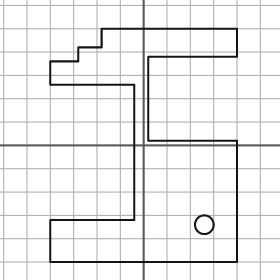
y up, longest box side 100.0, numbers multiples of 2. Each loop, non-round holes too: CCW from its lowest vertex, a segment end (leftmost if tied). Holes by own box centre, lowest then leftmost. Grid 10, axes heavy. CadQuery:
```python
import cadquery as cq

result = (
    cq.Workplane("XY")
    .moveTo(-40.0, -50.0)
    .lineTo(40.0, -50.0)
    .lineTo(40.0, 2.0)
    .lineTo(2.0, 2.0)
    .lineTo(2.0, 38.0)
    .lineTo(40.0, 38.0)
    .lineTo(40.0, 50.0)
    .lineTo(-18.0, 50.0)
    .lineTo(-18.0, 42.0)
    .lineTo(-28.0, 42.0)
    .lineTo(-28.0, 36.0)
    .lineTo(-40.0, 36.0)
    .lineTo(-40.0, 26.0)
    .lineTo(-4.0, 26.0)
    .lineTo(-4.0, -32.0)
    .lineTo(-40.0, -32.0)
    .close()
    .moveTo(26.0, -34.0)
    .circle(4.0)
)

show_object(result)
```